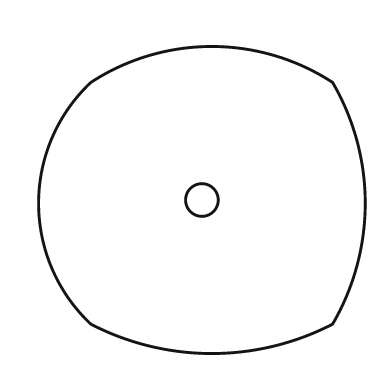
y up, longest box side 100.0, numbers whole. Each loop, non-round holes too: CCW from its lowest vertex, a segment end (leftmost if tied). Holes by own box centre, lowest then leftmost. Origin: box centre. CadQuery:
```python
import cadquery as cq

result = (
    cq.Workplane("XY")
    .moveTo(-34.0, -38.0)
    .threePointArc((3.0, -47.0), (40.0, -38.0))
    .threePointArc((50.0, -1.0), (40.0, 36.0))
    .threePointArc((3.0, 47.0), (-34.0, 36.0))
    .threePointArc((-50.0, -1.0), (-34.0, -38.0))
    .close()
    .moveTo(0.0, 0.0)
    .circle(5.0)
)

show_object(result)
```